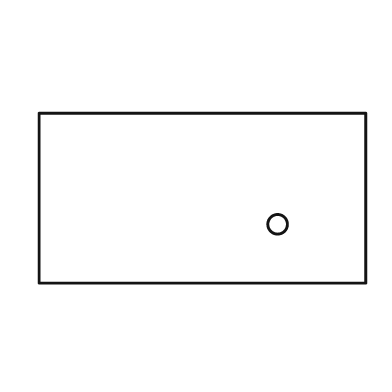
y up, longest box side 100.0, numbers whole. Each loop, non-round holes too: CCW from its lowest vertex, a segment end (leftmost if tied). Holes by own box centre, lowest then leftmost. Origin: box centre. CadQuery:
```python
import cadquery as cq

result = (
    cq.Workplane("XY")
    .moveTo(-50.0, -26.0)
    .lineTo(50.0, -26.0)
    .lineTo(50.0, 26.0)
    .lineTo(-50.0, 26.0)
    .close()
    .moveTo(23.0, -8.0)
    .circle(3.0)
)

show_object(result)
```